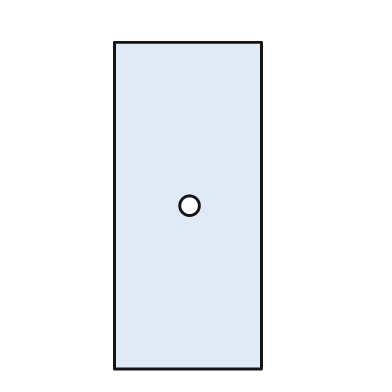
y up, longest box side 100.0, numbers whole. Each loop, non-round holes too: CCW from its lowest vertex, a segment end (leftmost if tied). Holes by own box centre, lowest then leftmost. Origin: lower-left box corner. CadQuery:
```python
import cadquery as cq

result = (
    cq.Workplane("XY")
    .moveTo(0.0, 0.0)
    .lineTo(45.0, 0.0)
    .lineTo(45.0, 100.0)
    .lineTo(0.0, 100.0)
    .close()
    .moveTo(23.0, 50.0)
    .circle(3.0)
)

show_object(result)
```